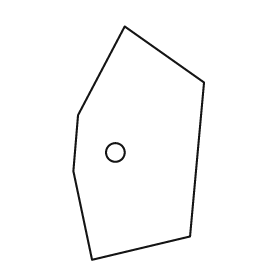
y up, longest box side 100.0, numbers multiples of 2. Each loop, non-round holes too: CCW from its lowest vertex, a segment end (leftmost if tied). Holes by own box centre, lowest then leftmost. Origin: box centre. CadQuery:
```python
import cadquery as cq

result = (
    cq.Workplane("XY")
    .moveTo(-20.0, -50.0)
    .lineTo(22.0, -40.0)
    .lineTo(28.0, 26.0)
    .lineTo(-6.0, 50.0)
    .lineTo(-26.0, 12.0)
    .lineTo(-28.0, -12.0)
    .close()
    .moveTo(-10.0, -4.0)
    .circle(4.0)
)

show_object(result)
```